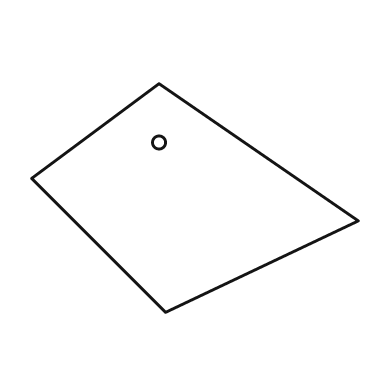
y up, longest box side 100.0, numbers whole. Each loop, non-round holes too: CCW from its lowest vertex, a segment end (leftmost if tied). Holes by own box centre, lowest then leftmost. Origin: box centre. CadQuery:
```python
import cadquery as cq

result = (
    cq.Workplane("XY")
    .moveTo(-9.0, -35.0)
    .lineTo(50.0, -7.0)
    .lineTo(-11.0, 35.0)
    .lineTo(-50.0, 6.0)
    .close()
    .moveTo(-11.0, 17.0)
    .circle(2.0)
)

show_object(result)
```